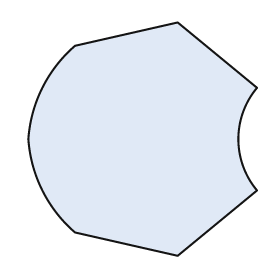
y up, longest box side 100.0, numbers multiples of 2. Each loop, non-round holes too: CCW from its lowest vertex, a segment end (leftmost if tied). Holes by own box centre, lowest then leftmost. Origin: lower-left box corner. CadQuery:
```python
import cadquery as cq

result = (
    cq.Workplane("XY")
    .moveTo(64.0, 0.0)
    .lineTo(98.0, 28.0)
    .threePointArc((90.0, 50.0), (98.0, 72.0))
    .lineTo(64.0, 100.0)
    .lineTo(20.0, 90.0)
    .threePointArc((6.0, 72.0), (0.0, 50.0))
    .threePointArc((6.0, 28.0), (20.0, 10.0))
    .close()
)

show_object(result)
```